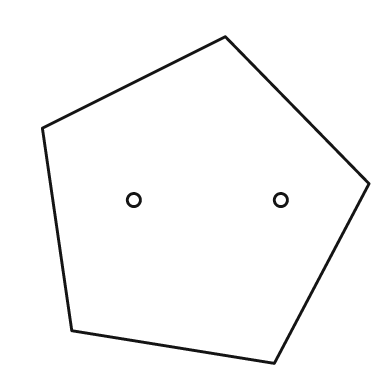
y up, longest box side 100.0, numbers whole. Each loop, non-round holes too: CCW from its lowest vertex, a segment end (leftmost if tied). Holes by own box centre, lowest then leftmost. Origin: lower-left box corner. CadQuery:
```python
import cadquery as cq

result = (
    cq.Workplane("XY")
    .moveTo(71.0, 0.0)
    .lineTo(100.0, 55.0)
    .lineTo(56.0, 100.0)
    .lineTo(0.0, 72.0)
    .lineTo(9.0, 10.0)
    .close()
    .moveTo(28.0, 50.0)
    .circle(2.0)
    .moveTo(73.0, 50.0)
    .circle(2.0)
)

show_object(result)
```